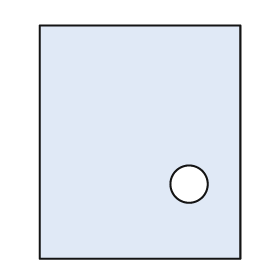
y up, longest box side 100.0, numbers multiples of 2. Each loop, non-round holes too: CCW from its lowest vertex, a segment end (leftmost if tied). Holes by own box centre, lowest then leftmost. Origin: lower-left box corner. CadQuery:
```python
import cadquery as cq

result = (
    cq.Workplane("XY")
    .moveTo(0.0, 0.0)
    .lineTo(86.0, 0.0)
    .lineTo(86.0, 100.0)
    .lineTo(0.0, 100.0)
    .close()
    .moveTo(64.0, 32.0)
    .circle(8.0)
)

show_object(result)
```